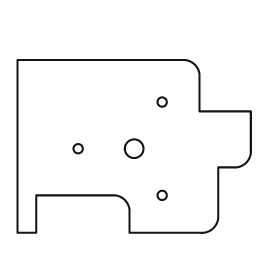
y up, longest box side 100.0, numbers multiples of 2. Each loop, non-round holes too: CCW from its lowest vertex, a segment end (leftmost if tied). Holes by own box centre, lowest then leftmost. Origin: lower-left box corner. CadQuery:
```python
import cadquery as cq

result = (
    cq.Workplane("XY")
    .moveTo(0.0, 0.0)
    .lineTo(8.0, 0.0)
    .lineTo(8.0, 16.0)
    .lineTo(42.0, 16.0)
    .threePointArc((46.0, 14.0), (48.0, 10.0))
    .lineTo(48.0, 0.0)
    .lineTo(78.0, 0.0)
    .threePointArc((84.0, 2.0), (86.0, 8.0))
    .lineTo(86.0, 28.0)
    .lineTo(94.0, 28.0)
    .threePointArc((98.0, 30.0), (100.0, 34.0))
    .lineTo(100.0, 52.0)
    .lineTo(78.0, 52.0)
    .lineTo(78.0, 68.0)
    .threePointArc((76.0, 72.0), (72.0, 74.0))
    .lineTo(0.0, 74.0)
    .close()
    .moveTo(62.0, 16.0)
    .circle(2.0)
    .moveTo(26.0, 36.0)
    .circle(2.0)
    .moveTo(50.0, 36.0)
    .circle(4.0)
    .moveTo(62.0, 56.0)
    .circle(2.0)
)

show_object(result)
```